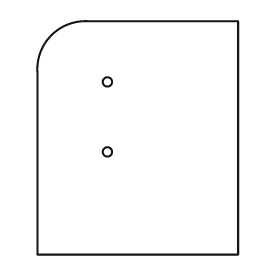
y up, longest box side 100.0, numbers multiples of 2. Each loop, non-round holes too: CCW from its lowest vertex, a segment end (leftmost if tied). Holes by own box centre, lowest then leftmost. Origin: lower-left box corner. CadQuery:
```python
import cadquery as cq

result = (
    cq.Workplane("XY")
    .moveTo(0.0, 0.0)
    .lineTo(86.0, 0.0)
    .lineTo(86.0, 100.0)
    .lineTo(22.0, 100.0)
    .threePointArc((6.0, 94.0), (0.0, 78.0))
    .close()
    .moveTo(30.0, 44.0)
    .circle(2.0)
    .moveTo(30.0, 74.0)
    .circle(2.0)
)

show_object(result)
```